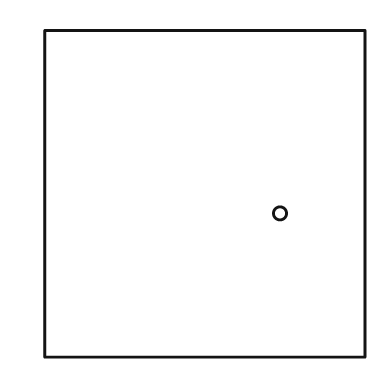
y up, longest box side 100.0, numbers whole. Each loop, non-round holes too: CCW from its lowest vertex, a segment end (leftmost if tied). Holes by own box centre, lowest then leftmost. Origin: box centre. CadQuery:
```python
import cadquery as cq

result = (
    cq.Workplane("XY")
    .moveTo(-49.0, -50.0)
    .lineTo(49.0, -50.0)
    .lineTo(49.0, 50.0)
    .lineTo(-49.0, 50.0)
    .close()
    .moveTo(23.0, -6.0)
    .circle(2.0)
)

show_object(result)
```